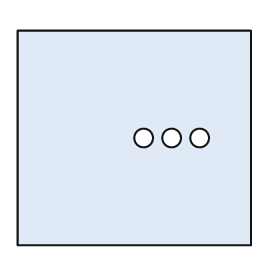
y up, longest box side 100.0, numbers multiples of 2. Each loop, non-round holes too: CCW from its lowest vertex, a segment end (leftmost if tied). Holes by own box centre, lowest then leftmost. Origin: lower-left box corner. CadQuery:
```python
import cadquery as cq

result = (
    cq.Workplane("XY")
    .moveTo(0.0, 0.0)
    .lineTo(100.0, 0.0)
    .lineTo(100.0, 92.0)
    .lineTo(0.0, 92.0)
    .close()
    .moveTo(54.0, 46.0)
    .circle(4.0)
    .moveTo(66.0, 46.0)
    .circle(4.0)
    .moveTo(78.0, 46.0)
    .circle(4.0)
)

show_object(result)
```